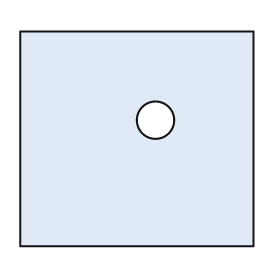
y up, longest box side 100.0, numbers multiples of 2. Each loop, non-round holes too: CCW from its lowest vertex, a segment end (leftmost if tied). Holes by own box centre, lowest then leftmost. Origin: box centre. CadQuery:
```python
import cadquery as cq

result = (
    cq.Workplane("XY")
    .moveTo(-50.0, -46.0)
    .lineTo(50.0, -46.0)
    .lineTo(50.0, 46.0)
    .lineTo(-50.0, 46.0)
    .close()
    .moveTo(8.0, 8.0)
    .circle(8.0)
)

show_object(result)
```